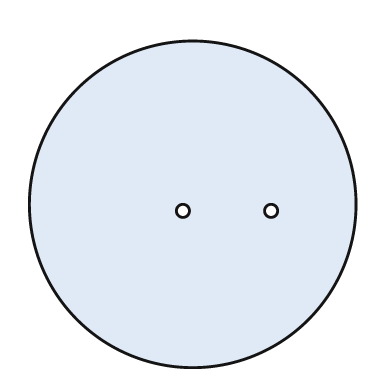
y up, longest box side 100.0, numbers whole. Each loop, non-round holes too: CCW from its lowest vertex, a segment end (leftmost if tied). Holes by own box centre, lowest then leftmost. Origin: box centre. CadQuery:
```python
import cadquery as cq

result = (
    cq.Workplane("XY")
    .moveTo(0.0, 0.0)
    .circle(50.0)
    .moveTo(-3.0, -2.0)
    .circle(2.0)
    .moveTo(24.0, -2.0)
    .circle(2.0)
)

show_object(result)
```